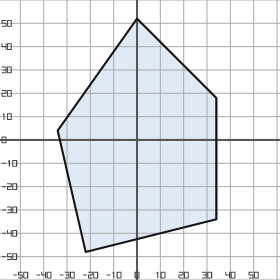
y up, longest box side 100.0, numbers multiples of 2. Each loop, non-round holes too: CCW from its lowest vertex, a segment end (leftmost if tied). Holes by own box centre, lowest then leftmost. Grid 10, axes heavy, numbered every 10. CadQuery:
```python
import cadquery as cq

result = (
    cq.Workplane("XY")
    .moveTo(-22.0, -48.0)
    .lineTo(34.0, -34.0)
    .lineTo(34.0, 18.0)
    .lineTo(0.0, 52.0)
    .lineTo(-34.0, 4.0)
    .close()
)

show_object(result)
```